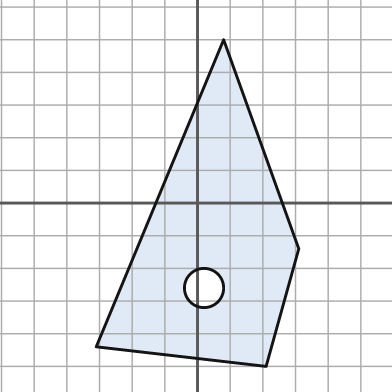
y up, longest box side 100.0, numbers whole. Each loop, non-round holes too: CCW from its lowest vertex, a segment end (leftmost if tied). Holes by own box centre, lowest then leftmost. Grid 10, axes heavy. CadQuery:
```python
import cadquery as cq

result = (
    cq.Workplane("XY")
    .moveTo(21.0, -50.0)
    .lineTo(31.0, -14.0)
    .lineTo(8.0, 50.0)
    .lineTo(-31.0, -44.0)
    .close()
    .moveTo(2.0, -26.0)
    .circle(6.0)
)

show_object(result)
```